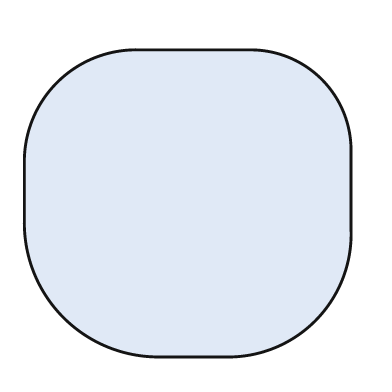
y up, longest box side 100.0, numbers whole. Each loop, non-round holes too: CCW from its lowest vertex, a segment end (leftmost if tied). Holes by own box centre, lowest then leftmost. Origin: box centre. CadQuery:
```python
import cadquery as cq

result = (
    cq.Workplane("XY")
    .moveTo(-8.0, -47.0)
    .lineTo(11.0, -47.0)
    .threePointArc((39.0, -36.0), (50.0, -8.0))
    .lineTo(50.0, 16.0)
    .threePointArc((41.0, 38.0), (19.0, 47.0))
    .lineTo(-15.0, 47.0)
    .threePointArc((-40.0, 37.0), (-50.0, 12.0))
    .lineTo(-50.0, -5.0)
    .threePointArc((-38.0, -35.0), (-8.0, -47.0))
    .close()
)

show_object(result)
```